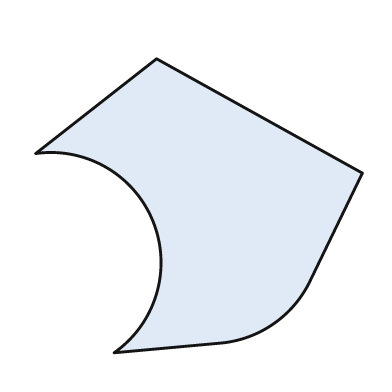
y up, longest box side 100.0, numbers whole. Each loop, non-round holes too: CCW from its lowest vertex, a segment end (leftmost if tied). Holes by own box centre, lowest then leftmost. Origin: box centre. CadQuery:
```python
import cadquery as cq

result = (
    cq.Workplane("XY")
    .moveTo(-26.0, -45.0)
    .lineTo(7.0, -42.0)
    .threePointArc((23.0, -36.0), (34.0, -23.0))
    .lineTo(50.0, 10.0)
    .lineTo(-13.0, 45.0)
    .lineTo(-50.0, 16.0)
    .threePointArc((-14.0, -5.0), (-26.0, -45.0))
    .close()
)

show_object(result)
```